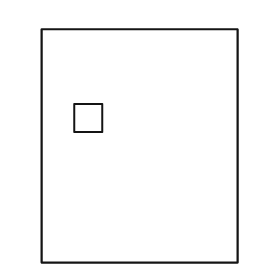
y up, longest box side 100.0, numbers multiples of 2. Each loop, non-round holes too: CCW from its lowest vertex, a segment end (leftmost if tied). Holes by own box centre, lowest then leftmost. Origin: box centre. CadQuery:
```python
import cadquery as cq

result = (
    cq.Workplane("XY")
    .moveTo(-42.0, -50.0)
    .lineTo(42.0, -50.0)
    .lineTo(42.0, 50.0)
    .lineTo(-42.0, 50.0)
    .close()
    .moveTo(-28.0, 6.0)
    .lineTo(-16.0, 6.0)
    .lineTo(-16.0, 18.0)
    .lineTo(-28.0, 18.0)
    .close()
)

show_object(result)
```